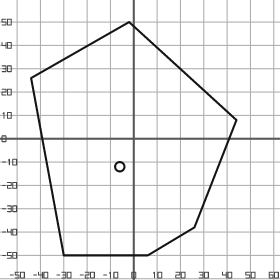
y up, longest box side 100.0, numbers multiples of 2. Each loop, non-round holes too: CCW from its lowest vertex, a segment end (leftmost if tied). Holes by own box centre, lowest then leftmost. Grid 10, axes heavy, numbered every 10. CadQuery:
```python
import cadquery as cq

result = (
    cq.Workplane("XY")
    .moveTo(-30.0, -50.0)
    .lineTo(6.0, -50.0)
    .lineTo(26.0, -38.0)
    .lineTo(44.0, 8.0)
    .lineTo(-2.0, 50.0)
    .lineTo(-44.0, 26.0)
    .close()
    .moveTo(-6.0, -12.0)
    .circle(2.0)
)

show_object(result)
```